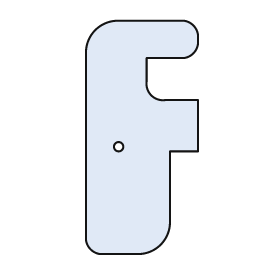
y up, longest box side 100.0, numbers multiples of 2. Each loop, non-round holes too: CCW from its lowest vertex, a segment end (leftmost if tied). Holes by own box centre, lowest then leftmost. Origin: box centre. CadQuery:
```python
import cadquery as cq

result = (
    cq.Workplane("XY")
    .moveTo(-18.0, -50.0)
    .lineTo(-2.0, -50.0)
    .threePointArc((8.0, -46.0), (12.0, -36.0))
    .lineTo(12.0, -6.0)
    .lineTo(24.0, -6.0)
    .lineTo(24.0, 16.0)
    .lineTo(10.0, 16.0)
    .threePointArc((4.0, 18.0), (2.0, 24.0))
    .lineTo(2.0, 34.0)
    .lineTo(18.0, 34.0)
    .threePointArc((22.0, 36.0), (24.0, 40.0))
    .lineTo(24.0, 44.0)
    .threePointArc((22.0, 48.0), (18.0, 50.0))
    .lineTo(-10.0, 50.0)
    .threePointArc((-20.0, 46.0), (-24.0, 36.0))
    .lineTo(-24.0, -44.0)
    .threePointArc((-22.0, -48.0), (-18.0, -50.0))
    .close()
    .moveTo(-10.0, -4.0)
    .circle(2.0)
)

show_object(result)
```